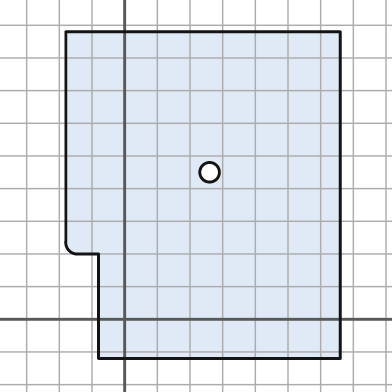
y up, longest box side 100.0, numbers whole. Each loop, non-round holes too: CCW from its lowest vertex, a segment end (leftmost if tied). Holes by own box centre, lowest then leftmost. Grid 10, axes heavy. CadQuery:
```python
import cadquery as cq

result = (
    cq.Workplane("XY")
    .moveTo(-8.0, -12.0)
    .lineTo(66.0, -12.0)
    .lineTo(66.0, 88.0)
    .lineTo(-18.0, 88.0)
    .lineTo(-18.0, 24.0)
    .threePointArc((-17.0, 21.0), (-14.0, 20.0))
    .lineTo(-8.0, 20.0)
    .close()
    .moveTo(26.0, 45.0)
    .circle(3.0)
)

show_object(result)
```